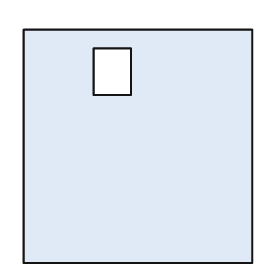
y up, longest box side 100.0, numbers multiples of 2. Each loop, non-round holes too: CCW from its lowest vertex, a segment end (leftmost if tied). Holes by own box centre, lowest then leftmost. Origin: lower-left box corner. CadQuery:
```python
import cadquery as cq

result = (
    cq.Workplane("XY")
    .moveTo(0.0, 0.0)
    .lineTo(98.0, 0.0)
    .lineTo(98.0, 100.0)
    .lineTo(0.0, 100.0)
    .close()
    .moveTo(30.0, 72.0)
    .lineTo(46.0, 72.0)
    .lineTo(46.0, 92.0)
    .lineTo(30.0, 92.0)
    .close()
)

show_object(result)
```